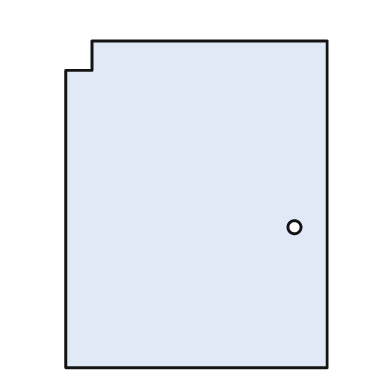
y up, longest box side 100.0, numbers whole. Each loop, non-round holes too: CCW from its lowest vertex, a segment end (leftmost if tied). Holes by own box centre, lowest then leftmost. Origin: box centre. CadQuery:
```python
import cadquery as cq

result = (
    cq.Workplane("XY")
    .moveTo(-40.0, -50.0)
    .lineTo(40.0, -50.0)
    .lineTo(40.0, 50.0)
    .lineTo(-32.0, 50.0)
    .lineTo(-32.0, 41.0)
    .lineTo(-40.0, 41.0)
    .close()
    .moveTo(30.0, -7.0)
    .circle(2.0)
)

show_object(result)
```